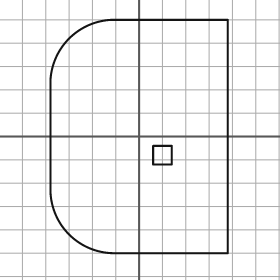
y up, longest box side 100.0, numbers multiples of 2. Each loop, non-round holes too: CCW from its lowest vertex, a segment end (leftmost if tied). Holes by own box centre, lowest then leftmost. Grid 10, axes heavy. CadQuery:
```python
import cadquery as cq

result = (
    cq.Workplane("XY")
    .moveTo(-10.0, -50.0)
    .lineTo(38.0, -50.0)
    .lineTo(38.0, 50.0)
    .lineTo(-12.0, 50.0)
    .threePointArc((-30.0, 42.0), (-38.0, 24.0))
    .lineTo(-38.0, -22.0)
    .threePointArc((-30.0, -42.0), (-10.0, -50.0))
    .close()
    .moveTo(6.0, -12.0)
    .lineTo(14.0, -12.0)
    .lineTo(14.0, -4.0)
    .lineTo(6.0, -4.0)
    .close()
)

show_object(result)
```